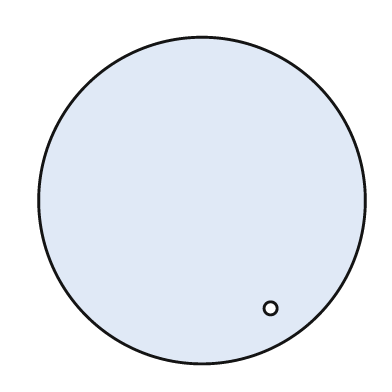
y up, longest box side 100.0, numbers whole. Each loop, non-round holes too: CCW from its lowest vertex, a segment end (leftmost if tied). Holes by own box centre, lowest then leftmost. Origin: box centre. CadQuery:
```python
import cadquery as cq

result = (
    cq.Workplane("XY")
    .moveTo(0.0, 0.0)
    .circle(50.0)
    .moveTo(21.0, -33.0)
    .circle(2.0)
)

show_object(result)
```